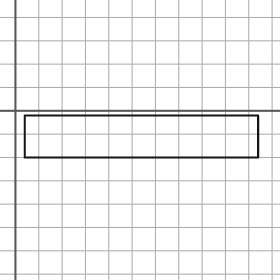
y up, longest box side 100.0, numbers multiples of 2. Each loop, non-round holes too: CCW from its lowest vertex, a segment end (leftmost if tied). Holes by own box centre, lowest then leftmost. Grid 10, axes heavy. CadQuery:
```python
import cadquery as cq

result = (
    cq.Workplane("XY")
    .moveTo(4.0, -20.0)
    .lineTo(104.0, -20.0)
    .lineTo(104.0, -2.0)
    .lineTo(4.0, -2.0)
    .close()
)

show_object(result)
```